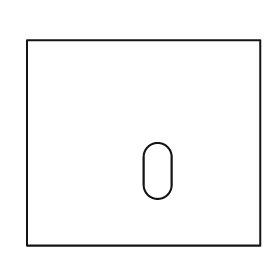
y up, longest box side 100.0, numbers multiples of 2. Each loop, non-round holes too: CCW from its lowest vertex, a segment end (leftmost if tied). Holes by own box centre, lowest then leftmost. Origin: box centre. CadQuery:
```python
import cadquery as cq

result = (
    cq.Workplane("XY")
    .moveTo(-50.0, -44.0)
    .lineTo(50.0, -44.0)
    .lineTo(50.0, 44.0)
    .lineTo(-50.0, 44.0)
    .close()
    .moveTo(0.0, -18.0)
    .threePointArc((6.0, -24.0), (12.0, -18.0))
    .lineTo(12.0, -6.0)
    .threePointArc((6.0, 0.0), (0.0, -6.0))
    .close()
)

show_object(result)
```